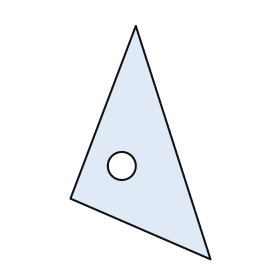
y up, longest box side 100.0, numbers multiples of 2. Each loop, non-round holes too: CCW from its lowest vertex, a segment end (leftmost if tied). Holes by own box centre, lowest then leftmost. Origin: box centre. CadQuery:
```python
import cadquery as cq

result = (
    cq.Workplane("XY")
    .moveTo(30.0, -50.0)
    .lineTo(-2.0, 50.0)
    .lineTo(-30.0, -24.0)
    .close()
    .moveTo(-8.0, -10.0)
    .circle(6.0)
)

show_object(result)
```